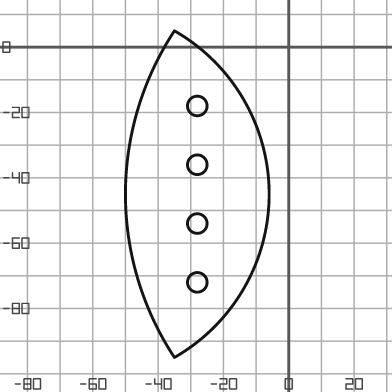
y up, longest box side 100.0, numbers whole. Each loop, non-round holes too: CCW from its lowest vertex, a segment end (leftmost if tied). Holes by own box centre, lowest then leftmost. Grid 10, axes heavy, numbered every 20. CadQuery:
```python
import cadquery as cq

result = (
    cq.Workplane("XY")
    .moveTo(-35.0, -95.0)
    .threePointArc((-6.0, -45.0), (-35.0, 5.0))
    .threePointArc((-50.0, -45.0), (-35.0, -95.0))
    .close()
    .moveTo(-28.0, -72.0)
    .circle(3.0)
    .moveTo(-28.0, -54.0)
    .circle(3.0)
    .moveTo(-28.0, -36.0)
    .circle(3.0)
    .moveTo(-28.0, -18.0)
    .circle(3.0)
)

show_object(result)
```